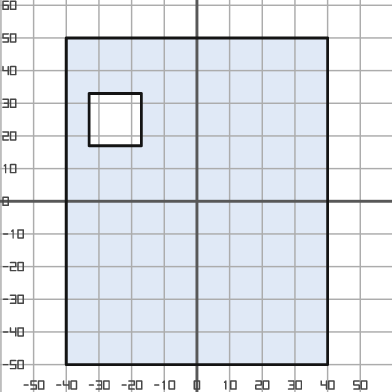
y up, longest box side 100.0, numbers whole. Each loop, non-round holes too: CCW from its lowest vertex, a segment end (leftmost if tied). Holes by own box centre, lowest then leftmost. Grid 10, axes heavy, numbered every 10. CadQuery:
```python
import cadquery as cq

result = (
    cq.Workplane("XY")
    .moveTo(-40.0, -50.0)
    .lineTo(40.0, -50.0)
    .lineTo(40.0, 50.0)
    .lineTo(-40.0, 50.0)
    .close()
    .moveTo(-33.0, 17.0)
    .lineTo(-17.0, 17.0)
    .lineTo(-17.0, 33.0)
    .lineTo(-33.0, 33.0)
    .close()
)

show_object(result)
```